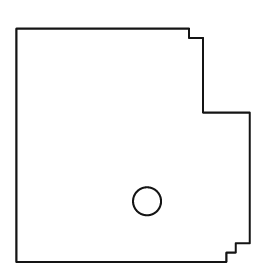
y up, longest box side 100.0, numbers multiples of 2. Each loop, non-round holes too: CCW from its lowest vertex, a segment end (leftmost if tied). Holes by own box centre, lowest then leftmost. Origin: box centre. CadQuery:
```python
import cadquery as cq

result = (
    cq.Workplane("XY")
    .moveTo(-50.0, -50.0)
    .lineTo(40.0, -50.0)
    .lineTo(40.0, -46.0)
    .lineTo(44.0, -46.0)
    .lineTo(44.0, -42.0)
    .lineTo(50.0, -42.0)
    .lineTo(50.0, 14.0)
    .lineTo(30.0, 14.0)
    .lineTo(30.0, 46.0)
    .lineTo(24.0, 46.0)
    .lineTo(24.0, 50.0)
    .lineTo(-50.0, 50.0)
    .close()
    .moveTo(6.0, -24.0)
    .circle(6.0)
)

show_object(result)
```